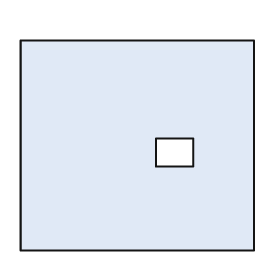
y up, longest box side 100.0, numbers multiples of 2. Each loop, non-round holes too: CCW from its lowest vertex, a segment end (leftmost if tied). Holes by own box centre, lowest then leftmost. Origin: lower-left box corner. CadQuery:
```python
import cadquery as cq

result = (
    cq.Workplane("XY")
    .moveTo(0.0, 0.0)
    .lineTo(100.0, 0.0)
    .lineTo(100.0, 90.0)
    .lineTo(0.0, 90.0)
    .close()
    .moveTo(58.0, 36.0)
    .lineTo(74.0, 36.0)
    .lineTo(74.0, 48.0)
    .lineTo(58.0, 48.0)
    .close()
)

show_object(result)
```